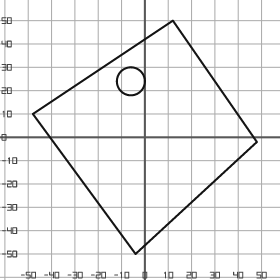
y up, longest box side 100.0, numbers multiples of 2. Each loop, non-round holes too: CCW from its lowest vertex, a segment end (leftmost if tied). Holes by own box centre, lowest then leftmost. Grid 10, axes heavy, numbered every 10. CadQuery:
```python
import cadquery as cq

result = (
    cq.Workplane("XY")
    .moveTo(-4.0, -50.0)
    .lineTo(48.0, -2.0)
    .lineTo(12.0, 50.0)
    .lineTo(-48.0, 10.0)
    .close()
    .moveTo(-6.0, 24.0)
    .circle(6.0)
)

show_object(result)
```